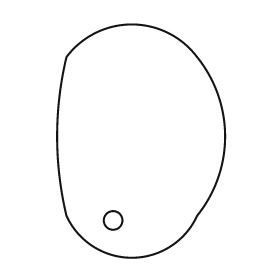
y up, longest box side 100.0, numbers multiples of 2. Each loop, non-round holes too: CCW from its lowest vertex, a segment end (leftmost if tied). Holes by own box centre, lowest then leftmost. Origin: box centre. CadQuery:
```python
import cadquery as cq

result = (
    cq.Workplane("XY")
    .moveTo(-32.0, -32.0)
    .threePointArc((-4.0, -50.0), (24.0, -32.0))
    .threePointArc((36.0, 2.0), (24.0, 36.0))
    .threePointArc((-4.0, 50.0), (-32.0, 36.0))
    .threePointArc((-36.0, 2.0), (-32.0, -32.0))
    .close()
    .moveTo(-12.0, -34.0)
    .circle(4.0)
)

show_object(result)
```